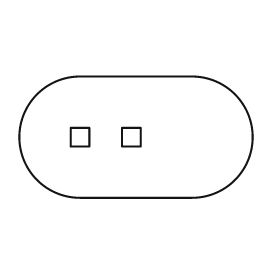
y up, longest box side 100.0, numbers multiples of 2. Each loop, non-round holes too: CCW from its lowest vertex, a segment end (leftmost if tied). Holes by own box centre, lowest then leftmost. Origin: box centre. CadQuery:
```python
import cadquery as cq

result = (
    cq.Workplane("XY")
    .moveTo(-24.0, -26.0)
    .lineTo(24.0, -26.0)
    .threePointArc((50.0, 0.0), (24.0, 26.0))
    .lineTo(-24.0, 26.0)
    .threePointArc((-50.0, 0.0), (-24.0, -26.0))
    .close()
    .moveTo(-28.0, -4.0)
    .lineTo(-20.0, -4.0)
    .lineTo(-20.0, 4.0)
    .lineTo(-28.0, 4.0)
    .close()
    .moveTo(-6.0, -4.0)
    .lineTo(2.0, -4.0)
    .lineTo(2.0, 4.0)
    .lineTo(-6.0, 4.0)
    .close()
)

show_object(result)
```